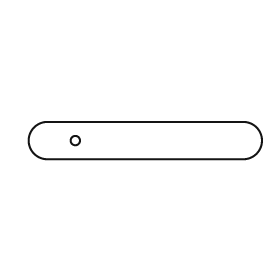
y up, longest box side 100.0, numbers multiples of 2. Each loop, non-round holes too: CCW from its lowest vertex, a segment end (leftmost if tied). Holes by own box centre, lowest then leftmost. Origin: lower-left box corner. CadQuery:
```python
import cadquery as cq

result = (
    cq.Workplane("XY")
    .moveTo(8.0, 0.0)
    .lineTo(92.0, 0.0)
    .threePointArc((100.0, 8.0), (92.0, 16.0))
    .lineTo(8.0, 16.0)
    .threePointArc((0.0, 8.0), (8.0, 0.0))
    .close()
    .moveTo(20.0, 8.0)
    .circle(2.0)
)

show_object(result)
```